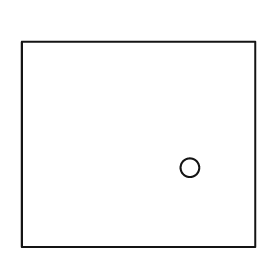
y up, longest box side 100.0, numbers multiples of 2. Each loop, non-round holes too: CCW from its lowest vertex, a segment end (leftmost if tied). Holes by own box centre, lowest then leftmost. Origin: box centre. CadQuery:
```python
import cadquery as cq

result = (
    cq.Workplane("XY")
    .moveTo(-50.0, -44.0)
    .lineTo(50.0, -44.0)
    .lineTo(50.0, 44.0)
    .lineTo(-50.0, 44.0)
    .close()
    .moveTo(22.0, -10.0)
    .circle(4.0)
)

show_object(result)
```